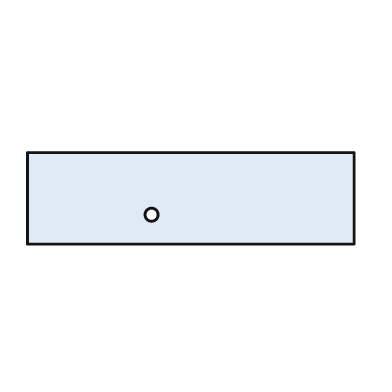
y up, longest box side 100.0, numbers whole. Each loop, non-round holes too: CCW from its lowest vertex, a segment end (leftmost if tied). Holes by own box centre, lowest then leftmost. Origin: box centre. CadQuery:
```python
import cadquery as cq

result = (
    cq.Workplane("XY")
    .moveTo(-50.0, -14.0)
    .lineTo(50.0, -14.0)
    .lineTo(50.0, 14.0)
    .lineTo(-50.0, 14.0)
    .close()
    .moveTo(-12.0, -5.0)
    .circle(2.0)
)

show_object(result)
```